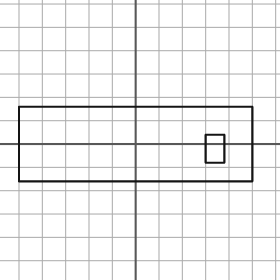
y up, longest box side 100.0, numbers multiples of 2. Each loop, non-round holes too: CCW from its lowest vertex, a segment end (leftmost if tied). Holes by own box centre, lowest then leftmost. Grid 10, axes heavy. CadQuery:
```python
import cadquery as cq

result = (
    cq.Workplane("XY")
    .moveTo(-50.0, -16.0)
    .lineTo(50.0, -16.0)
    .lineTo(50.0, 16.0)
    .lineTo(-50.0, 16.0)
    .close()
    .moveTo(30.0, -8.0)
    .lineTo(38.0, -8.0)
    .lineTo(38.0, 4.0)
    .lineTo(30.0, 4.0)
    .close()
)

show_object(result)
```